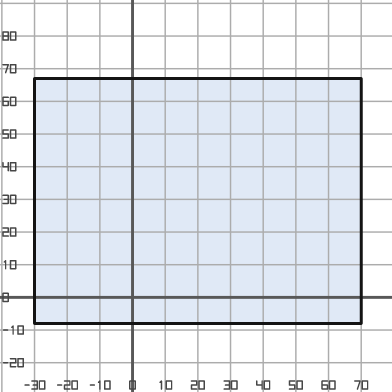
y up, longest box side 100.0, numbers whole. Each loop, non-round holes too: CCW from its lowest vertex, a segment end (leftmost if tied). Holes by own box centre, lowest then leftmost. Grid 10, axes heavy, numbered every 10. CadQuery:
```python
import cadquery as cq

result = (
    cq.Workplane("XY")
    .moveTo(-30.0, -8.0)
    .lineTo(70.0, -8.0)
    .lineTo(70.0, 67.0)
    .lineTo(-30.0, 67.0)
    .close()
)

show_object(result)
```